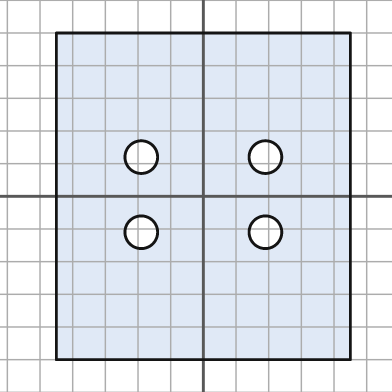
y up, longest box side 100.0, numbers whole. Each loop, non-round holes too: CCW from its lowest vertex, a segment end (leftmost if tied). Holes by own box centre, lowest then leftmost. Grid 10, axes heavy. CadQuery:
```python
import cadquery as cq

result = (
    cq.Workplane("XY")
    .moveTo(-45.0, -50.0)
    .lineTo(45.0, -50.0)
    .lineTo(45.0, 50.0)
    .lineTo(-45.0, 50.0)
    .close()
    .moveTo(-19.0, -11.0)
    .circle(5.0)
    .moveTo(19.0, -11.0)
    .circle(5.0)
    .moveTo(-19.0, 12.0)
    .circle(5.0)
    .moveTo(19.0, 12.0)
    .circle(5.0)
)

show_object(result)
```